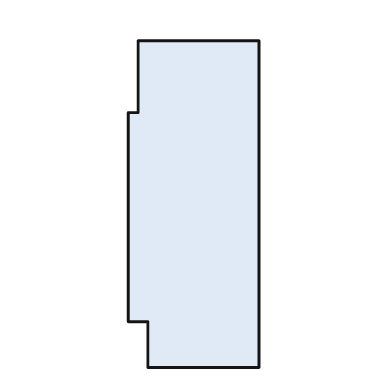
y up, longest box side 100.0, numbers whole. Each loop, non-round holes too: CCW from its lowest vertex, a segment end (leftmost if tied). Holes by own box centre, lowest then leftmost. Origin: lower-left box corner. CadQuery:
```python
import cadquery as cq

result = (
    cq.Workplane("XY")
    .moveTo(6.0, 0.0)
    .lineTo(40.0, 0.0)
    .lineTo(40.0, 100.0)
    .lineTo(3.0, 100.0)
    .lineTo(3.0, 78.0)
    .lineTo(0.0, 78.0)
    .lineTo(0.0, 14.0)
    .lineTo(6.0, 14.0)
    .close()
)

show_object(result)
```